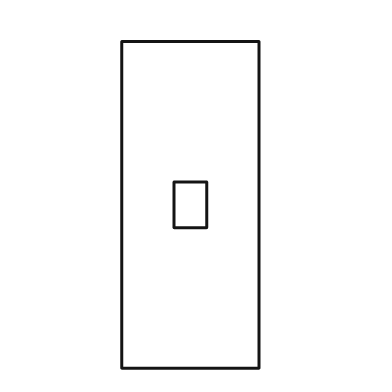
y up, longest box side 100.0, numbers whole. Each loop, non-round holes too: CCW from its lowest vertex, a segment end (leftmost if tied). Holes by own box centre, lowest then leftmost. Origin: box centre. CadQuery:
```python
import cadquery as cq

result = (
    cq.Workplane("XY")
    .moveTo(-21.0, -50.0)
    .lineTo(21.0, -50.0)
    .lineTo(21.0, 50.0)
    .lineTo(-21.0, 50.0)
    .close()
    .moveTo(-5.0, -7.0)
    .lineTo(5.0, -7.0)
    .lineTo(5.0, 7.0)
    .lineTo(-5.0, 7.0)
    .close()
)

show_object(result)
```